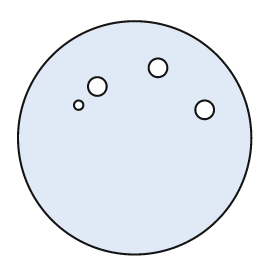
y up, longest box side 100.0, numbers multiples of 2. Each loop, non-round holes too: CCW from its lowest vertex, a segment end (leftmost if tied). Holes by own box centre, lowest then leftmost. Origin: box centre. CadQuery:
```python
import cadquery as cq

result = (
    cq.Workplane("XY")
    .moveTo(0.0, 0.0)
    .circle(50.0)
    .moveTo(30.0, 12.0)
    .circle(4.0)
    .moveTo(-24.0, 14.0)
    .circle(2.0)
    .moveTo(-16.0, 22.0)
    .circle(4.0)
    .moveTo(10.0, 30.0)
    .circle(4.0)
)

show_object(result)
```